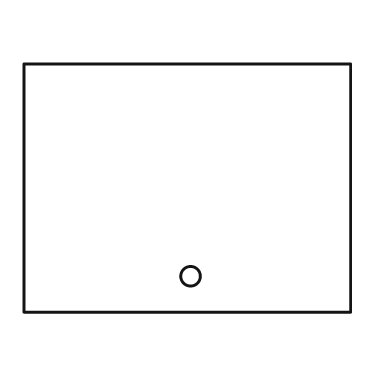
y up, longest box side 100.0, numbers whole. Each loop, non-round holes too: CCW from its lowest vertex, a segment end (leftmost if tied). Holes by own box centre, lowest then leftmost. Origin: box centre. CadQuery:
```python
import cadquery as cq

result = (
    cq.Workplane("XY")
    .moveTo(-50.0, -38.0)
    .lineTo(50.0, -38.0)
    .lineTo(50.0, 38.0)
    .lineTo(-50.0, 38.0)
    .close()
    .moveTo(1.0, -27.0)
    .circle(3.0)
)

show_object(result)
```